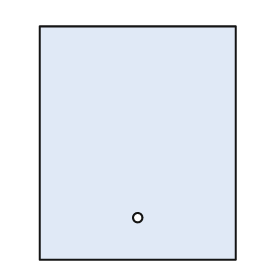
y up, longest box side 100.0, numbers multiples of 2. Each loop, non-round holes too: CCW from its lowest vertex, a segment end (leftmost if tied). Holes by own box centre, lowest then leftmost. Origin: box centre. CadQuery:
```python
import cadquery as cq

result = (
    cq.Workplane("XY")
    .moveTo(-42.0, -50.0)
    .lineTo(42.0, -50.0)
    .lineTo(42.0, 50.0)
    .lineTo(-42.0, 50.0)
    .close()
    .moveTo(0.0, -32.0)
    .circle(2.0)
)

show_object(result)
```